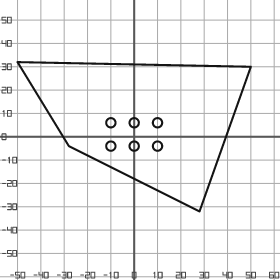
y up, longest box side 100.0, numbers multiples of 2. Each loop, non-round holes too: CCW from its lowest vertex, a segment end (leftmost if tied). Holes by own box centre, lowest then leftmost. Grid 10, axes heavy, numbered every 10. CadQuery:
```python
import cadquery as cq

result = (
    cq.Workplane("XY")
    .moveTo(28.0, -32.0)
    .lineTo(50.0, 30.0)
    .lineTo(-50.0, 32.0)
    .lineTo(-28.0, -4.0)
    .close()
    .moveTo(-10.0, -4.0)
    .circle(2.0)
    .moveTo(0.0, -4.0)
    .circle(2.0)
    .moveTo(10.0, -4.0)
    .circle(2.0)
    .moveTo(-10.0, 6.0)
    .circle(2.0)
    .moveTo(0.0, 6.0)
    .circle(2.0)
    .moveTo(10.0, 6.0)
    .circle(2.0)
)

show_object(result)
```